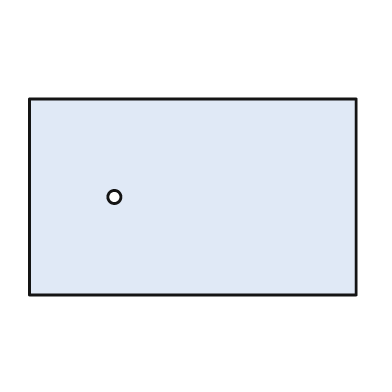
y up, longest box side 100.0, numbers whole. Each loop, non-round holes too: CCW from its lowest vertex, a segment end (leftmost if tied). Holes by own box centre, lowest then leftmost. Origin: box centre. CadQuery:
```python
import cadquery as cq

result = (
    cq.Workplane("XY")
    .moveTo(-50.0, -30.0)
    .lineTo(50.0, -30.0)
    .lineTo(50.0, 30.0)
    .lineTo(-50.0, 30.0)
    .close()
    .moveTo(-24.0, 0.0)
    .circle(2.0)
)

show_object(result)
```